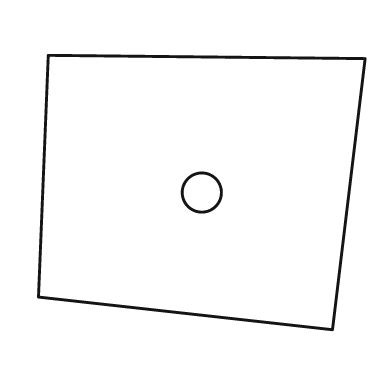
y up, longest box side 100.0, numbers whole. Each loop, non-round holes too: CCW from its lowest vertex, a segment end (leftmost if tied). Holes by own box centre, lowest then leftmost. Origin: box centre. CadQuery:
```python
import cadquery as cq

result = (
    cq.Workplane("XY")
    .moveTo(40.0, -42.0)
    .lineTo(50.0, 41.0)
    .lineTo(-47.0, 42.0)
    .lineTo(-50.0, -32.0)
    .close()
    .moveTo(0.0, 0.0)
    .circle(6.0)
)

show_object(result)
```